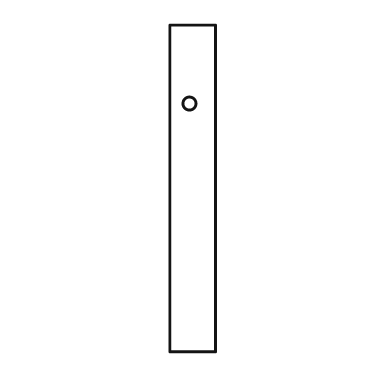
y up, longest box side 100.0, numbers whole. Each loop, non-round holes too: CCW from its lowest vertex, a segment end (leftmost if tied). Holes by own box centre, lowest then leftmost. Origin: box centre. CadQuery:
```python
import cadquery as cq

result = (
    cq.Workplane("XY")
    .moveTo(-7.0, -50.0)
    .lineTo(7.0, -50.0)
    .lineTo(7.0, 50.0)
    .lineTo(-7.0, 50.0)
    .close()
    .moveTo(-1.0, 26.0)
    .circle(2.0)
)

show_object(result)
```